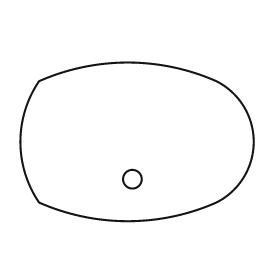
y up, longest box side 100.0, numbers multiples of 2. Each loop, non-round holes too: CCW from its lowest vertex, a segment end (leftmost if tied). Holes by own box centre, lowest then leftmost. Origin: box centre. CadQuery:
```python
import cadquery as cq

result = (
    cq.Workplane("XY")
    .moveTo(-42.0, -26.0)
    .threePointArc((-4.0, -34.0), (34.0, -26.0))
    .threePointArc((50.0, 0.0), (34.0, 26.0))
    .threePointArc((-4.0, 34.0), (-42.0, 26.0))
    .threePointArc((-50.0, 0.0), (-42.0, -26.0))
    .close()
    .moveTo(-2.0, -16.0)
    .circle(4.0)
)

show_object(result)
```